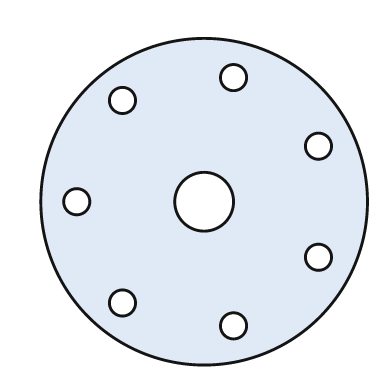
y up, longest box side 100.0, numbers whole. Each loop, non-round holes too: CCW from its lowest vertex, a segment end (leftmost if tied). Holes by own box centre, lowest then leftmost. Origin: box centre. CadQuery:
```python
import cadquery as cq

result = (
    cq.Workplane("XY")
    .moveTo(0.0, 0.0)
    .circle(50.0)
    .moveTo(9.0, -38.0)
    .circle(4.0)
    .moveTo(-25.0, -31.0)
    .circle(4.0)
    .moveTo(35.0, -17.0)
    .circle(4.0)
    .moveTo(-39.0, 0.0)
    .circle(4.0)
    .moveTo(0.0, 0.0)
    .circle(9.0)
    .moveTo(35.0, 17.0)
    .circle(4.0)
    .moveTo(-25.0, 31.0)
    .circle(4.0)
    .moveTo(9.0, 38.0)
    .circle(4.0)
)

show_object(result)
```